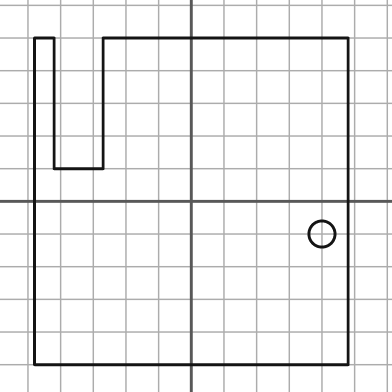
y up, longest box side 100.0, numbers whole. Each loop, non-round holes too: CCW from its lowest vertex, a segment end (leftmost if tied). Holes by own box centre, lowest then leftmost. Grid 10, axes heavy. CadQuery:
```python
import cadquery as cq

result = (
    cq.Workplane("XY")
    .moveTo(-48.0, -50.0)
    .lineTo(48.0, -50.0)
    .lineTo(48.0, 50.0)
    .lineTo(-27.0, 50.0)
    .lineTo(-27.0, 10.0)
    .lineTo(-42.0, 10.0)
    .lineTo(-42.0, 50.0)
    .lineTo(-48.0, 50.0)
    .close()
    .moveTo(40.0, -10.0)
    .circle(4.0)
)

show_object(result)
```